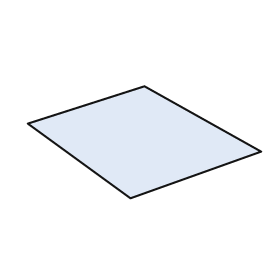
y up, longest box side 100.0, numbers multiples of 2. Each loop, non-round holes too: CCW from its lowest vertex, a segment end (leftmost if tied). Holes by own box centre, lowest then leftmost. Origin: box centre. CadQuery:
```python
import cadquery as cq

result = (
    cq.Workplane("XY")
    .moveTo(-6.0, -24.0)
    .lineTo(50.0, -4.0)
    .lineTo(0.0, 24.0)
    .lineTo(-50.0, 8.0)
    .close()
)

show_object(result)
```